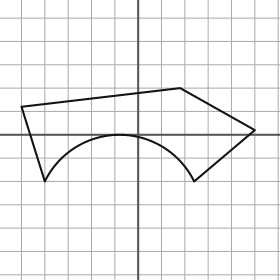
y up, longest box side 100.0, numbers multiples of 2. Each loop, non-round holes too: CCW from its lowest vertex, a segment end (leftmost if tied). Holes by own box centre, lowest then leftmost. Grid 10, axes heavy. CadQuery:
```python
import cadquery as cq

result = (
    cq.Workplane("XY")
    .moveTo(-40.0, -20.0)
    .threePointArc((-8.0, 0.0), (24.0, -20.0))
    .lineTo(50.0, 2.0)
    .lineTo(18.0, 20.0)
    .lineTo(-50.0, 12.0)
    .close()
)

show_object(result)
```